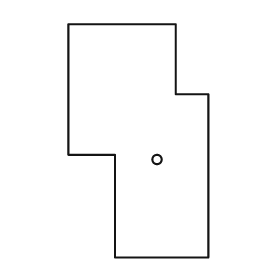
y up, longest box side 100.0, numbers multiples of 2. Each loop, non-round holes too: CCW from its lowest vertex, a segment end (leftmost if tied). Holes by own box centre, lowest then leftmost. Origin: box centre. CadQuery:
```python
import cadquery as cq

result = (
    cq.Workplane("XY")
    .moveTo(-10.0, -50.0)
    .lineTo(30.0, -50.0)
    .lineTo(30.0, 20.0)
    .lineTo(16.0, 20.0)
    .lineTo(16.0, 50.0)
    .lineTo(-30.0, 50.0)
    .lineTo(-30.0, -6.0)
    .lineTo(-10.0, -6.0)
    .close()
    .moveTo(8.0, -8.0)
    .circle(2.0)
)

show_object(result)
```